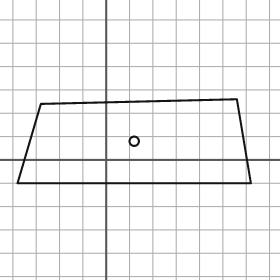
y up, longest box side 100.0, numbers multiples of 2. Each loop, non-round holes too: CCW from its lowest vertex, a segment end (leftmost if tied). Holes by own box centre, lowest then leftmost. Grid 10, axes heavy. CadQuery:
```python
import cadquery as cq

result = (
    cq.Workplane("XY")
    .moveTo(-38.0, -10.0)
    .lineTo(62.0, -10.0)
    .lineTo(56.0, 26.0)
    .lineTo(-28.0, 24.0)
    .close()
    .moveTo(12.0, 8.0)
    .circle(2.0)
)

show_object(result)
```